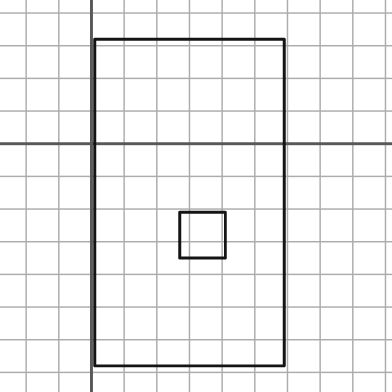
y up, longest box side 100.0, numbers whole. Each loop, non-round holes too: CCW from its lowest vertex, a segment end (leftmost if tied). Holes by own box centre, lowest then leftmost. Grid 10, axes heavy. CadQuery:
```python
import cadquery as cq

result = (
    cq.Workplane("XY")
    .moveTo(1.0, -68.0)
    .lineTo(59.0, -68.0)
    .lineTo(59.0, 32.0)
    .lineTo(1.0, 32.0)
    .close()
    .moveTo(27.0, -35.0)
    .lineTo(41.0, -35.0)
    .lineTo(41.0, -21.0)
    .lineTo(27.0, -21.0)
    .close()
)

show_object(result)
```